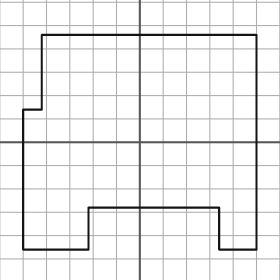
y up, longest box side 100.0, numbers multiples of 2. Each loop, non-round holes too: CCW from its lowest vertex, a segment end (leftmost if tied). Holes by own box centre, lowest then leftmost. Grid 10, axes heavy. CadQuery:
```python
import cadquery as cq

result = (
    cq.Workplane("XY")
    .moveTo(-50.0, -46.0)
    .lineTo(-22.0, -46.0)
    .lineTo(-22.0, -28.0)
    .lineTo(34.0, -28.0)
    .lineTo(34.0, -46.0)
    .lineTo(50.0, -46.0)
    .lineTo(50.0, 46.0)
    .lineTo(-42.0, 46.0)
    .lineTo(-42.0, 14.0)
    .lineTo(-50.0, 14.0)
    .close()
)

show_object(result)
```